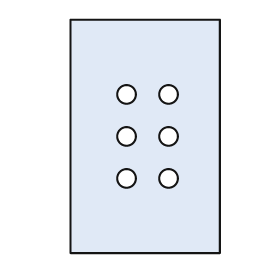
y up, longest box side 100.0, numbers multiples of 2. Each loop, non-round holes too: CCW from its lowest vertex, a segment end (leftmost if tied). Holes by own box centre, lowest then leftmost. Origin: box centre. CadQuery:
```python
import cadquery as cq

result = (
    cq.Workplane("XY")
    .moveTo(-32.0, -50.0)
    .lineTo(32.0, -50.0)
    .lineTo(32.0, 50.0)
    .lineTo(-32.0, 50.0)
    .close()
    .moveTo(-8.0, -18.0)
    .circle(4.0)
    .moveTo(10.0, -18.0)
    .circle(4.0)
    .moveTo(-8.0, 0.0)
    .circle(4.0)
    .moveTo(10.0, 0.0)
    .circle(4.0)
    .moveTo(-8.0, 18.0)
    .circle(4.0)
    .moveTo(10.0, 18.0)
    .circle(4.0)
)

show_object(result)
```